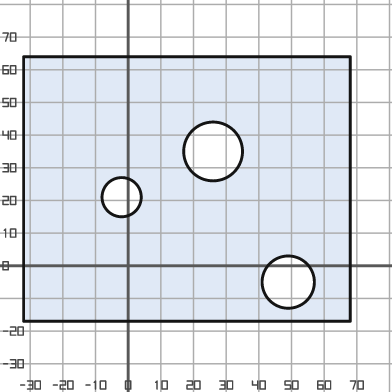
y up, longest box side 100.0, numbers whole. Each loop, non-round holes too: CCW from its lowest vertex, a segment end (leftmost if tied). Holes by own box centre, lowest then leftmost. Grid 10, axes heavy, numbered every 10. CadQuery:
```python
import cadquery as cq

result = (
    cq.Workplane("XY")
    .moveTo(-32.0, -17.0)
    .lineTo(68.0, -17.0)
    .lineTo(68.0, 64.0)
    .lineTo(-32.0, 64.0)
    .close()
    .moveTo(49.0, -5.0)
    .circle(8.0)
    .moveTo(-2.0, 21.0)
    .circle(6.0)
    .moveTo(26.0, 35.0)
    .circle(9.0)
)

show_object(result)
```